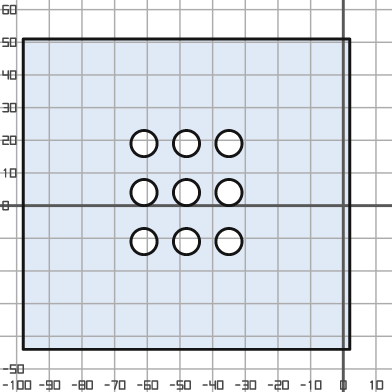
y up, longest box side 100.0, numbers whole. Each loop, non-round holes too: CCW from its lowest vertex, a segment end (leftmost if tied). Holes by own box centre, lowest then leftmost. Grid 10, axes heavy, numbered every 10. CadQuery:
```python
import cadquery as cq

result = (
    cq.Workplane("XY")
    .moveTo(-98.0, -44.0)
    .lineTo(2.0, -44.0)
    .lineTo(2.0, 51.0)
    .lineTo(-98.0, 51.0)
    .close()
    .moveTo(-61.0, -11.0)
    .circle(4.0)
    .moveTo(-48.0, -11.0)
    .circle(4.0)
    .moveTo(-35.0, -11.0)
    .circle(4.0)
    .moveTo(-61.0, 4.0)
    .circle(4.0)
    .moveTo(-48.0, 4.0)
    .circle(4.0)
    .moveTo(-35.0, 4.0)
    .circle(4.0)
    .moveTo(-61.0, 19.0)
    .circle(4.0)
    .moveTo(-48.0, 19.0)
    .circle(4.0)
    .moveTo(-35.0, 19.0)
    .circle(4.0)
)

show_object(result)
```